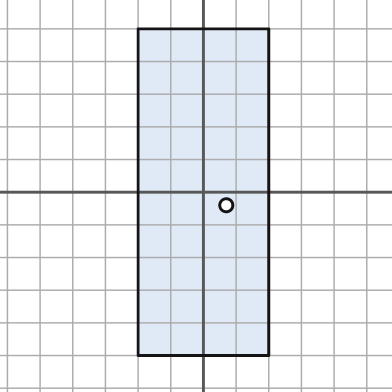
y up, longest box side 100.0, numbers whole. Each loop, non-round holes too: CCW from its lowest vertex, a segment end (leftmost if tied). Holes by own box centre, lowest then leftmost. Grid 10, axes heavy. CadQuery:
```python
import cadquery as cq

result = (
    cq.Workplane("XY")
    .moveTo(-20.0, -50.0)
    .lineTo(20.0, -50.0)
    .lineTo(20.0, 50.0)
    .lineTo(-20.0, 50.0)
    .close()
    .moveTo(7.0, -4.0)
    .circle(2.0)
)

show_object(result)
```